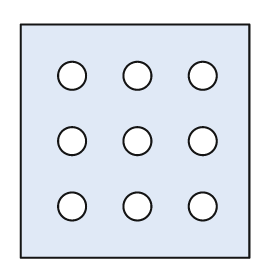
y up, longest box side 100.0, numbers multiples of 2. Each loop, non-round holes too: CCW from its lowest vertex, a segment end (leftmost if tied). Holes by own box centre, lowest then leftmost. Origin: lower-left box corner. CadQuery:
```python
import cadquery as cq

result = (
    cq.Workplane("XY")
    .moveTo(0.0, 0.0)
    .lineTo(98.0, 0.0)
    .lineTo(98.0, 100.0)
    .lineTo(0.0, 100.0)
    .close()
    .moveTo(22.0, 22.0)
    .circle(6.0)
    .moveTo(50.0, 22.0)
    .circle(6.0)
    .moveTo(78.0, 22.0)
    .circle(6.0)
    .moveTo(22.0, 50.0)
    .circle(6.0)
    .moveTo(50.0, 50.0)
    .circle(6.0)
    .moveTo(78.0, 50.0)
    .circle(6.0)
    .moveTo(22.0, 78.0)
    .circle(6.0)
    .moveTo(50.0, 78.0)
    .circle(6.0)
    .moveTo(78.0, 78.0)
    .circle(6.0)
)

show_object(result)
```